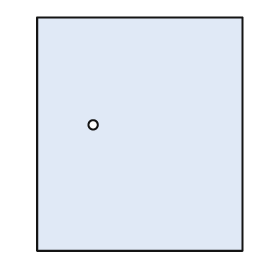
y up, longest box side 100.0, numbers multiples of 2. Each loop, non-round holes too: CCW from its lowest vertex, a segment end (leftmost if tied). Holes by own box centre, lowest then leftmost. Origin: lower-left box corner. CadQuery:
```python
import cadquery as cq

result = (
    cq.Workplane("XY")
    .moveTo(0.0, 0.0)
    .lineTo(88.0, 0.0)
    .lineTo(88.0, 100.0)
    .lineTo(0.0, 100.0)
    .close()
    .moveTo(24.0, 54.0)
    .circle(2.0)
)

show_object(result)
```